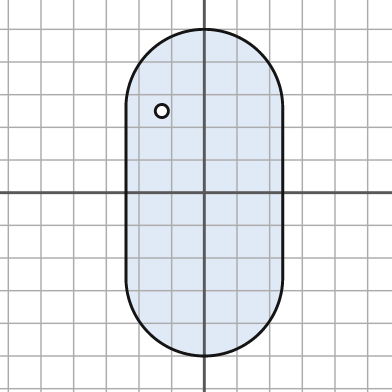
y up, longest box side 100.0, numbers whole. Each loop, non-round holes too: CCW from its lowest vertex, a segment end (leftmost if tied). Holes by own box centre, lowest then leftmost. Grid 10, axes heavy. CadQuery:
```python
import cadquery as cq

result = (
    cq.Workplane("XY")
    .moveTo(-24.0, -26.0)
    .threePointArc((0.0, -50.0), (24.0, -26.0))
    .lineTo(24.0, 26.0)
    .threePointArc((0.0, 50.0), (-24.0, 26.0))
    .close()
    .moveTo(-13.0, 25.0)
    .circle(2.0)
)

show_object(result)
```